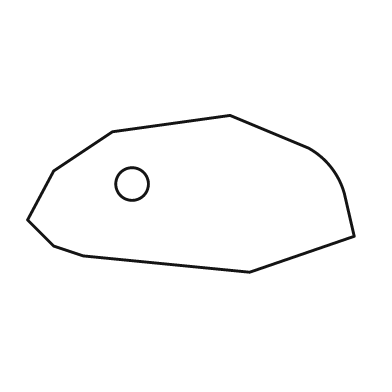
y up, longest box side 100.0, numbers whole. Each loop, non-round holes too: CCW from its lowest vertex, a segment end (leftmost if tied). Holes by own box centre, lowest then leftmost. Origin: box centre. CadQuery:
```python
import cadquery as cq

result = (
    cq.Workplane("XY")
    .moveTo(18.0, -24.0)
    .lineTo(50.0, -13.0)
    .lineTo(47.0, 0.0)
    .threePointArc((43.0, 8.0), (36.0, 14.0))
    .lineTo(12.0, 24.0)
    .lineTo(-24.0, 19.0)
    .lineTo(-42.0, 7.0)
    .lineTo(-50.0, -8.0)
    .lineTo(-42.0, -16.0)
    .lineTo(-33.0, -19.0)
    .close()
    .moveTo(-18.0, 3.0)
    .circle(5.0)
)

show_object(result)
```